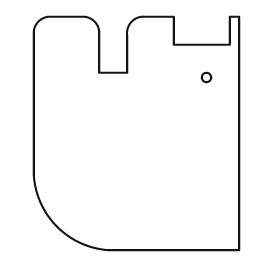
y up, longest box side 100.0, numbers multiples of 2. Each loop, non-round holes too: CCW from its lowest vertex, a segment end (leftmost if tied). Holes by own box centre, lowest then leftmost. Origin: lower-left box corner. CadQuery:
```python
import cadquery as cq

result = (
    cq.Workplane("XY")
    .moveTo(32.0, 0.0)
    .lineTo(88.0, 0.0)
    .lineTo(88.0, 100.0)
    .lineTo(84.0, 100.0)
    .lineTo(84.0, 88.0)
    .lineTo(60.0, 88.0)
    .lineTo(60.0, 100.0)
    .lineTo(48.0, 100.0)
    .threePointArc((42.0, 98.0), (40.0, 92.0))
    .lineTo(40.0, 76.0)
    .lineTo(28.0, 76.0)
    .lineTo(28.0, 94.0)
    .threePointArc((26.0, 98.0), (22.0, 100.0))
    .lineTo(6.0, 100.0)
    .threePointArc((2.0, 98.0), (0.0, 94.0))
    .lineTo(0.0, 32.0)
    .threePointArc((10.0, 10.0), (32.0, 0.0))
    .close()
    .moveTo(74.0, 74.0)
    .circle(2.0)
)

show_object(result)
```